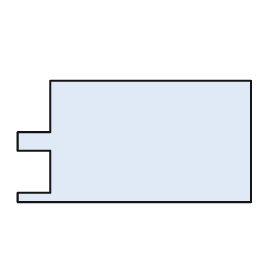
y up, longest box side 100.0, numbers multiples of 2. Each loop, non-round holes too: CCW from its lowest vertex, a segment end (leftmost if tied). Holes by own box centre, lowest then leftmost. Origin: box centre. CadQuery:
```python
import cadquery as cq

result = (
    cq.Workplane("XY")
    .moveTo(-50.0, -26.0)
    .lineTo(50.0, -26.0)
    .lineTo(50.0, 26.0)
    .lineTo(-36.0, 26.0)
    .lineTo(-36.0, 4.0)
    .lineTo(-50.0, 4.0)
    .lineTo(-50.0, -4.0)
    .lineTo(-36.0, -4.0)
    .lineTo(-36.0, -22.0)
    .lineTo(-50.0, -22.0)
    .close()
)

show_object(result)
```